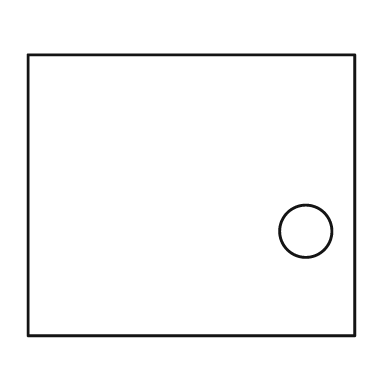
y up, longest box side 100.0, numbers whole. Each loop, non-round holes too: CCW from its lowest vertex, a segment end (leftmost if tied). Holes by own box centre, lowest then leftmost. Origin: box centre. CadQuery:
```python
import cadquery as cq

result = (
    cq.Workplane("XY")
    .moveTo(-50.0, -43.0)
    .lineTo(50.0, -43.0)
    .lineTo(50.0, 43.0)
    .lineTo(-50.0, 43.0)
    .close()
    .moveTo(35.0, -11.0)
    .circle(8.0)
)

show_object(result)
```